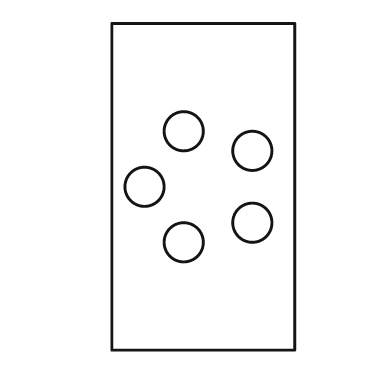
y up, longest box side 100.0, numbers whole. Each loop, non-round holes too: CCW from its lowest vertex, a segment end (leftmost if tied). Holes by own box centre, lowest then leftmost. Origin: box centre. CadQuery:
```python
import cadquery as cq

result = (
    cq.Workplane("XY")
    .moveTo(-28.0, -50.0)
    .lineTo(28.0, -50.0)
    .lineTo(28.0, 50.0)
    .lineTo(-28.0, 50.0)
    .close()
    .moveTo(-6.0, -17.0)
    .circle(6.0)
    .moveTo(15.0, -11.0)
    .circle(6.0)
    .moveTo(-18.0, 0.0)
    .circle(6.0)
    .moveTo(15.0, 11.0)
    .circle(6.0)
    .moveTo(-6.0, 17.0)
    .circle(6.0)
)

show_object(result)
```